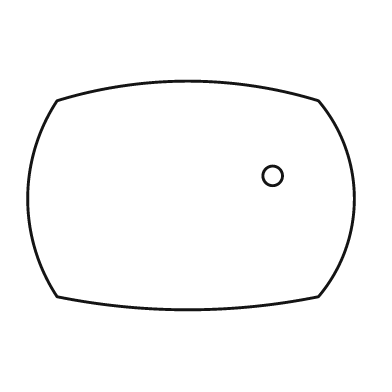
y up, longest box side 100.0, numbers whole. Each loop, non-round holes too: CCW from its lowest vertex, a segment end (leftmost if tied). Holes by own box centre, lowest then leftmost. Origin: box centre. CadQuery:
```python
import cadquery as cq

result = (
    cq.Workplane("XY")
    .moveTo(-41.0, -31.0)
    .threePointArc((-1.0, -35.0), (39.0, -31.0))
    .threePointArc((50.0, -1.0), (39.0, 29.0))
    .threePointArc((-1.0, 35.0), (-41.0, 29.0))
    .threePointArc((-50.0, -1.0), (-41.0, -31.0))
    .close()
    .moveTo(25.0, 6.0)
    .circle(3.0)
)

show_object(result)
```